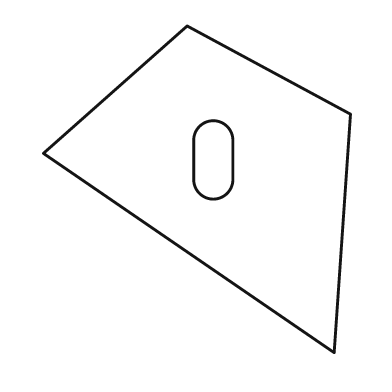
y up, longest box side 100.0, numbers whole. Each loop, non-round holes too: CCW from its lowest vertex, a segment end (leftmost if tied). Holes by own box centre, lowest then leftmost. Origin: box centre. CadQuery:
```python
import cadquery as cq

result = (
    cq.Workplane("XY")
    .moveTo(42.0, -50.0)
    .lineTo(47.0, 23.0)
    .lineTo(-3.0, 50.0)
    .lineTo(-47.0, 11.0)
    .close()
    .moveTo(-1.0, 3.0)
    .threePointArc((5.0, -3.0), (11.0, 3.0))
    .lineTo(11.0, 15.0)
    .threePointArc((5.0, 21.0), (-1.0, 15.0))
    .close()
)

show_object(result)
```